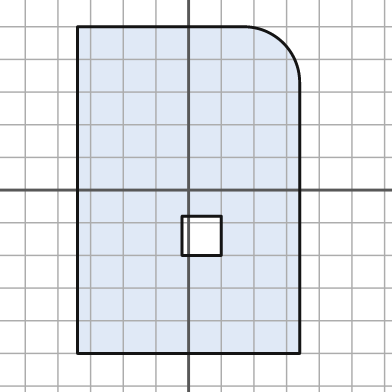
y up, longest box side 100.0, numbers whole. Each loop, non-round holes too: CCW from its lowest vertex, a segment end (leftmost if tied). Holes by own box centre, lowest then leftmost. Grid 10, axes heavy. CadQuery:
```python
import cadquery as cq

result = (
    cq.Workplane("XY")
    .moveTo(-34.0, -50.0)
    .lineTo(34.0, -50.0)
    .lineTo(34.0, 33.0)
    .threePointArc((29.0, 45.0), (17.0, 50.0))
    .lineTo(-34.0, 50.0)
    .close()
    .moveTo(-2.0, -20.0)
    .lineTo(10.0, -20.0)
    .lineTo(10.0, -8.0)
    .lineTo(-2.0, -8.0)
    .close()
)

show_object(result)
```